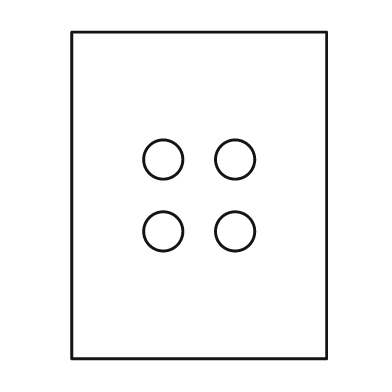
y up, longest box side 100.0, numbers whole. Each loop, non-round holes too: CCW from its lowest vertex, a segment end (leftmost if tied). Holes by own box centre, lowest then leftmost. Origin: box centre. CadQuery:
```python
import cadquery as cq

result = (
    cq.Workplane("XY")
    .moveTo(-39.0, -50.0)
    .lineTo(39.0, -50.0)
    .lineTo(39.0, 50.0)
    .lineTo(-39.0, 50.0)
    .close()
    .moveTo(-11.0, -11.0)
    .circle(6.0)
    .moveTo(11.0, -11.0)
    .circle(6.0)
    .moveTo(-11.0, 11.0)
    .circle(6.0)
    .moveTo(11.0, 11.0)
    .circle(6.0)
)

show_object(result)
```